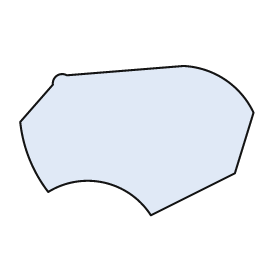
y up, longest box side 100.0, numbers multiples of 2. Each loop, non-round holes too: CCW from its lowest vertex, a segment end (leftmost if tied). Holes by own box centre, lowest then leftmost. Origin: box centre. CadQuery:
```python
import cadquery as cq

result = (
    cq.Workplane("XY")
    .moveTo(6.0, -32.0)
    .lineTo(42.0, -14.0)
    .lineTo(50.0, 12.0)
    .threePointArc((38.0, 26.0), (20.0, 32.0))
    .lineTo(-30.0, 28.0)
    .threePointArc((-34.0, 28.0), (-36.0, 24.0))
    .lineTo(-50.0, 8.0)
    .threePointArc((-46.0, -8.0), (-38.0, -22.0))
    .threePointArc((-14.0, -18.0), (6.0, -32.0))
    .close()
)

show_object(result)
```